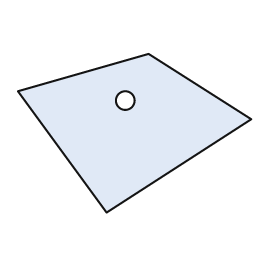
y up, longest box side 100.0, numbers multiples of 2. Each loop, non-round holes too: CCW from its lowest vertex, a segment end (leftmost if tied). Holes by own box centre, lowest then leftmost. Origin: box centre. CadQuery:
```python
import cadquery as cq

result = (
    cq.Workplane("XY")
    .moveTo(-12.0, -34.0)
    .lineTo(50.0, 6.0)
    .lineTo(6.0, 34.0)
    .lineTo(-50.0, 18.0)
    .close()
    .moveTo(-4.0, 14.0)
    .circle(4.0)
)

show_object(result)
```